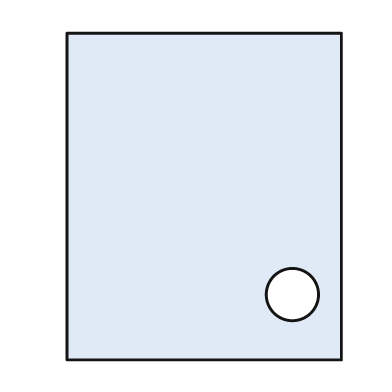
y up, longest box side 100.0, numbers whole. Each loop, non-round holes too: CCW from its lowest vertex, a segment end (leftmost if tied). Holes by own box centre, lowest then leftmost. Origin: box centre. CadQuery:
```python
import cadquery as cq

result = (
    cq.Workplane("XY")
    .moveTo(-42.0, -50.0)
    .lineTo(42.0, -50.0)
    .lineTo(42.0, 50.0)
    .lineTo(-42.0, 50.0)
    .close()
    .moveTo(27.0, -30.0)
    .circle(8.0)
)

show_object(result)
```